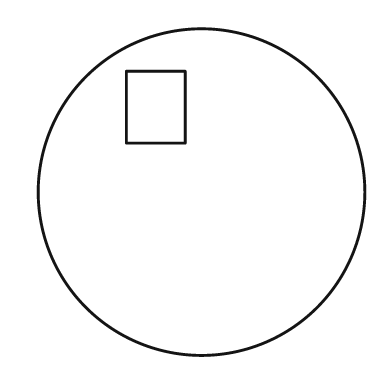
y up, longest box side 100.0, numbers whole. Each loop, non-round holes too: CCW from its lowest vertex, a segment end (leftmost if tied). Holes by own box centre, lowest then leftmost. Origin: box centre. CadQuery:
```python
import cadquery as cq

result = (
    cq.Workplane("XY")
    .moveTo(0.0, 0.0)
    .circle(50.0)
    .moveTo(-23.0, 15.0)
    .lineTo(-5.0, 15.0)
    .lineTo(-5.0, 37.0)
    .lineTo(-23.0, 37.0)
    .close()
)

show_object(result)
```